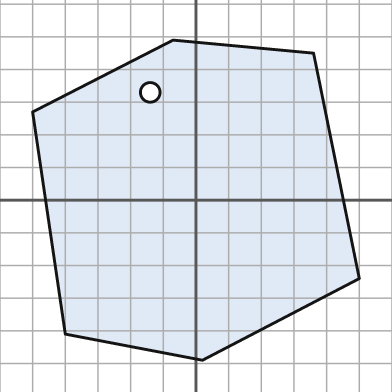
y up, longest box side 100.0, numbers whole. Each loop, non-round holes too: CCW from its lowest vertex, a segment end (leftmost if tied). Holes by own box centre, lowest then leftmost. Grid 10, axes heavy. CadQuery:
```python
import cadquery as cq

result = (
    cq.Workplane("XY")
    .moveTo(2.0, -49.0)
    .lineTo(50.0, -24.0)
    .lineTo(36.0, 45.0)
    .lineTo(-7.0, 49.0)
    .lineTo(-50.0, 27.0)
    .lineTo(-40.0, -41.0)
    .close()
    .moveTo(-14.0, 33.0)
    .circle(3.0)
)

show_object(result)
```